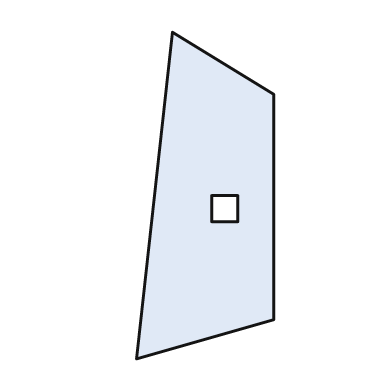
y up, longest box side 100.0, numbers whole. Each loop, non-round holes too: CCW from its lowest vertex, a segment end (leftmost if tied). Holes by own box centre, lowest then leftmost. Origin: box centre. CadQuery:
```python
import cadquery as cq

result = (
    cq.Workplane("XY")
    .moveTo(-21.0, -50.0)
    .lineTo(21.0, -38.0)
    .lineTo(21.0, 31.0)
    .lineTo(-10.0, 50.0)
    .close()
    .moveTo(2.0, -8.0)
    .lineTo(10.0, -8.0)
    .lineTo(10.0, 0.0)
    .lineTo(2.0, 0.0)
    .close()
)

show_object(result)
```